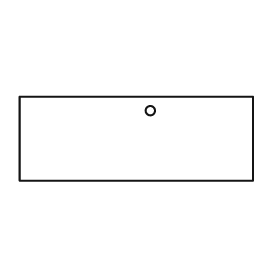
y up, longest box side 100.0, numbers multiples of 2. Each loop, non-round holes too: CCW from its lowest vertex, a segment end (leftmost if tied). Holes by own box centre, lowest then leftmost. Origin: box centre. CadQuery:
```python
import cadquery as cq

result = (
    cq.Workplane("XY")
    .moveTo(-50.0, -18.0)
    .lineTo(50.0, -18.0)
    .lineTo(50.0, 18.0)
    .lineTo(-50.0, 18.0)
    .close()
    .moveTo(6.0, 12.0)
    .circle(2.0)
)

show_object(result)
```